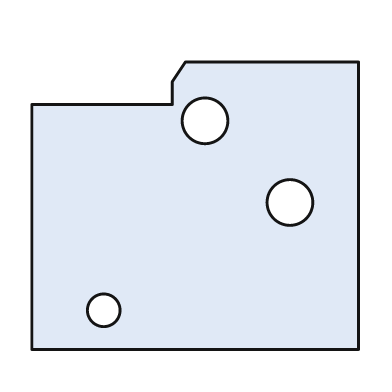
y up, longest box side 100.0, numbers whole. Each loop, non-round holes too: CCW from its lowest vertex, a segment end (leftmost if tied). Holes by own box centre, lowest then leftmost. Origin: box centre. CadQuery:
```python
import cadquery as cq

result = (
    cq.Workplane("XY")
    .moveTo(-50.0, -44.0)
    .lineTo(50.0, -44.0)
    .lineTo(50.0, 44.0)
    .lineTo(-3.0, 44.0)
    .lineTo(-7.0, 38.0)
    .lineTo(-7.0, 31.0)
    .lineTo(-50.0, 31.0)
    .close()
    .moveTo(-28.0, -32.0)
    .circle(5.0)
    .moveTo(29.0, 1.0)
    .circle(7.0)
    .moveTo(3.0, 26.0)
    .circle(7.0)
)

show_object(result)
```